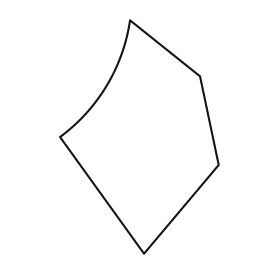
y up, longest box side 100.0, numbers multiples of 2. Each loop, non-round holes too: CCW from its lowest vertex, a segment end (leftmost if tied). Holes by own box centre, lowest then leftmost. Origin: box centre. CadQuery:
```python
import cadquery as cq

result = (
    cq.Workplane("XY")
    .moveTo(2.0, -50.0)
    .lineTo(34.0, -12.0)
    .lineTo(26.0, 26.0)
    .lineTo(-4.0, 50.0)
    .threePointArc((-14.0, 22.0), (-34.0, 0.0))
    .close()
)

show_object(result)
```